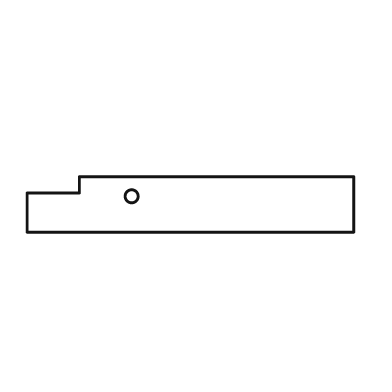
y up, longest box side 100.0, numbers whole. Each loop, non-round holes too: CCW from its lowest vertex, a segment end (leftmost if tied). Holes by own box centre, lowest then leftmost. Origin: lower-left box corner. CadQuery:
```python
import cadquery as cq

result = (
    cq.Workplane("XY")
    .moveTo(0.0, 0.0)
    .lineTo(100.0, 0.0)
    .lineTo(100.0, 17.0)
    .lineTo(16.0, 17.0)
    .lineTo(16.0, 12.0)
    .lineTo(0.0, 12.0)
    .close()
    .moveTo(32.0, 11.0)
    .circle(2.0)
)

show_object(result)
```